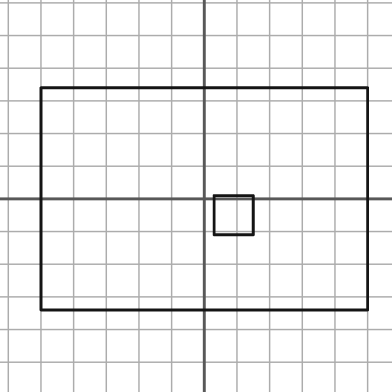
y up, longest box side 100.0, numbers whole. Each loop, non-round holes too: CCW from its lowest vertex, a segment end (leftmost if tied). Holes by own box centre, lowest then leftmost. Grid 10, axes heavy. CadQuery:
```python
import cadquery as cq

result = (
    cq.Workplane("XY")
    .moveTo(-50.0, -34.0)
    .lineTo(50.0, -34.0)
    .lineTo(50.0, 34.0)
    .lineTo(-50.0, 34.0)
    .close()
    .moveTo(3.0, -11.0)
    .lineTo(15.0, -11.0)
    .lineTo(15.0, 1.0)
    .lineTo(3.0, 1.0)
    .close()
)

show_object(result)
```